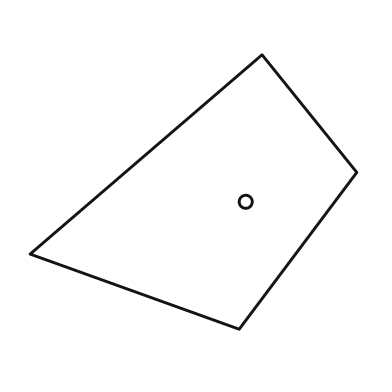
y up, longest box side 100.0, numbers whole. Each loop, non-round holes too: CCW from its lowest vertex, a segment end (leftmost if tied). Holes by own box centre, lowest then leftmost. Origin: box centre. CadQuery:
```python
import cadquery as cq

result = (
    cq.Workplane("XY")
    .moveTo(14.0, -42.0)
    .lineTo(50.0, 6.0)
    .lineTo(21.0, 42.0)
    .lineTo(-50.0, -19.0)
    .close()
    .moveTo(16.0, -3.0)
    .circle(2.0)
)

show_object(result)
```